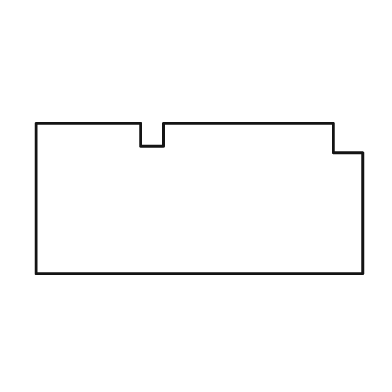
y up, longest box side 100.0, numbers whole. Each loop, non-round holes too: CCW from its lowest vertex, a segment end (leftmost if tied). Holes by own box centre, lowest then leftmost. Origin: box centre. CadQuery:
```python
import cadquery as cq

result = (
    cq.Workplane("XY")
    .moveTo(-50.0, -23.0)
    .lineTo(50.0, -23.0)
    .lineTo(50.0, 14.0)
    .lineTo(41.0, 14.0)
    .lineTo(41.0, 23.0)
    .lineTo(-11.0, 23.0)
    .lineTo(-11.0, 16.0)
    .lineTo(-18.0, 16.0)
    .lineTo(-18.0, 23.0)
    .lineTo(-50.0, 23.0)
    .close()
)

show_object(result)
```